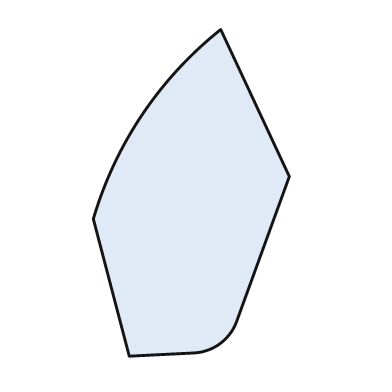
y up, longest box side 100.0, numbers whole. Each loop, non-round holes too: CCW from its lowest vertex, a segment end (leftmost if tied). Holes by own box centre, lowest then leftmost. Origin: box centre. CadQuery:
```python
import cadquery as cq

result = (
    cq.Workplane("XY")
    .moveTo(-19.0, -50.0)
    .lineTo(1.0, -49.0)
    .threePointArc((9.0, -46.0), (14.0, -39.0))
    .lineTo(30.0, 5.0)
    .lineTo(9.0, 50.0)
    .threePointArc((-15.0, 24.0), (-30.0, -8.0))
    .close()
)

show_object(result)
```